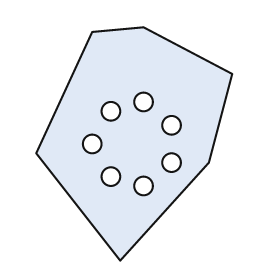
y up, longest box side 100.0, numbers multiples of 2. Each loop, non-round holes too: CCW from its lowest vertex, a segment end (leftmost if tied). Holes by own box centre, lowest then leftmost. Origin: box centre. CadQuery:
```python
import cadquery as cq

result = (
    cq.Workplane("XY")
    .moveTo(-6.0, -50.0)
    .lineTo(32.0, -8.0)
    .lineTo(42.0, 30.0)
    .lineTo(4.0, 50.0)
    .lineTo(-18.0, 48.0)
    .lineTo(-42.0, -4.0)
    .close()
    .moveTo(4.0, -18.0)
    .circle(4.0)
    .moveTo(-10.0, -14.0)
    .circle(4.0)
    .moveTo(16.0, -8.0)
    .circle(4.0)
    .moveTo(-18.0, 0.0)
    .circle(4.0)
    .moveTo(16.0, 8.0)
    .circle(4.0)
    .moveTo(-10.0, 14.0)
    .circle(4.0)
    .moveTo(4.0, 18.0)
    .circle(4.0)
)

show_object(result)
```